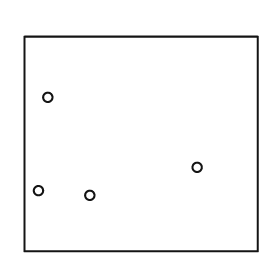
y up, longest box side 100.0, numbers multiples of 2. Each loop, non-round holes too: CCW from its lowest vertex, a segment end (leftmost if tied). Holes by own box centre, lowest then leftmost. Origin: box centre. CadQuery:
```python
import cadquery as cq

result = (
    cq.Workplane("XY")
    .moveTo(-50.0, -46.0)
    .lineTo(50.0, -46.0)
    .lineTo(50.0, 46.0)
    .lineTo(-50.0, 46.0)
    .close()
    .moveTo(-22.0, -22.0)
    .circle(2.0)
    .moveTo(-44.0, -20.0)
    .circle(2.0)
    .moveTo(24.0, -10.0)
    .circle(2.0)
    .moveTo(-40.0, 20.0)
    .circle(2.0)
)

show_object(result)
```